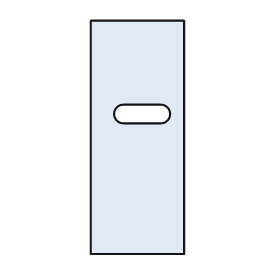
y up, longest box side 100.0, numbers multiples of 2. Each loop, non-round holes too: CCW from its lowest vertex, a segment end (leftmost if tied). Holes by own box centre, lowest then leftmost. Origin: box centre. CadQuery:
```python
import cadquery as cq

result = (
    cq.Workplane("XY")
    .moveTo(-20.0, -50.0)
    .lineTo(20.0, -50.0)
    .lineTo(20.0, 50.0)
    .lineTo(-20.0, 50.0)
    .close()
    .moveTo(-6.0, 6.0)
    .lineTo(10.0, 6.0)
    .threePointArc((14.0, 10.0), (10.0, 14.0))
    .lineTo(-6.0, 14.0)
    .threePointArc((-10.0, 10.0), (-6.0, 6.0))
    .close()
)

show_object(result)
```